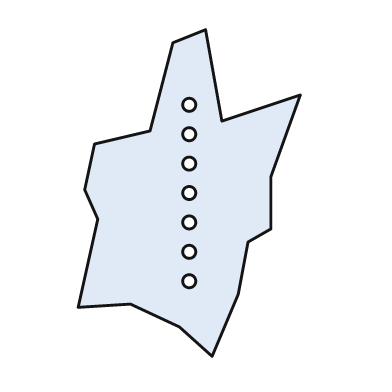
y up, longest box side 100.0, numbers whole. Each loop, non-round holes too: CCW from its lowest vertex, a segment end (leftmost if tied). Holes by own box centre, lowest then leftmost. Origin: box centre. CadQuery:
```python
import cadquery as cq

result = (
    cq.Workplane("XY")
    .moveTo(7.0, -50.0)
    .lineTo(15.0, -31.0)
    .lineTo(18.0, -15.0)
    .lineTo(25.0, -11.0)
    .lineTo(25.0, 5.0)
    .lineTo(34.0, 30.0)
    .lineTo(10.0, 22.0)
    .lineTo(5.0, 50.0)
    .lineTo(-5.0, 46.0)
    .lineTo(-12.0, 19.0)
    .lineTo(-29.0, 15.0)
    .lineTo(-32.0, 1.0)
    .lineTo(-28.0, -8.0)
    .lineTo(-34.0, -35.0)
    .lineTo(-18.0, -34.0)
    .lineTo(-3.0, -41.0)
    .close()
    .moveTo(0.0, -27.0)
    .circle(2.0)
    .moveTo(0.0, -18.0)
    .circle(2.0)
    .moveTo(0.0, -9.0)
    .circle(2.0)
    .moveTo(0.0, 0.0)
    .circle(2.0)
    .moveTo(0.0, 9.0)
    .circle(2.0)
    .moveTo(0.0, 18.0)
    .circle(2.0)
    .moveTo(0.0, 27.0)
    .circle(2.0)
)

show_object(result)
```